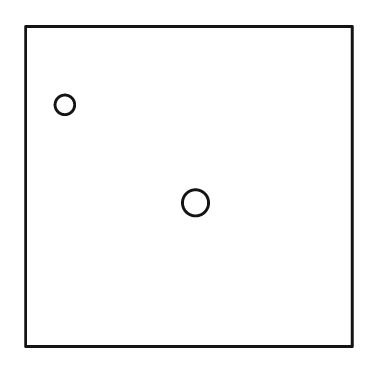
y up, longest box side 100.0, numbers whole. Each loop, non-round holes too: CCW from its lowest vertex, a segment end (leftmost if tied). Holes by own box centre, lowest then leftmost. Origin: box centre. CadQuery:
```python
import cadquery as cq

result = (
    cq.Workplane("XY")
    .moveTo(-50.0, -49.0)
    .lineTo(50.0, -49.0)
    .lineTo(50.0, 49.0)
    .lineTo(-50.0, 49.0)
    .close()
    .moveTo(2.0, -5.0)
    .circle(4.0)
    .moveTo(-38.0, 25.0)
    .circle(3.0)
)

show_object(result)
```